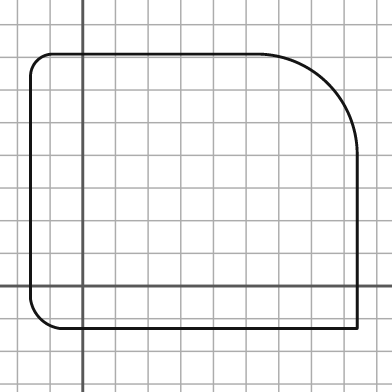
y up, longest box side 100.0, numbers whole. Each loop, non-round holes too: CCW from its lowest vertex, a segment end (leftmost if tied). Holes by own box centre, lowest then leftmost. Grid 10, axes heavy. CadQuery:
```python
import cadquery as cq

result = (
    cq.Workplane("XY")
    .moveTo(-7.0, -13.0)
    .lineTo(84.0, -13.0)
    .lineTo(84.0, 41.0)
    .threePointArc((75.0, 62.0), (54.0, 71.0))
    .lineTo(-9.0, 71.0)
    .threePointArc((-14.0, 69.0), (-16.0, 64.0))
    .lineTo(-16.0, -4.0)
    .threePointArc((-13.0, -10.0), (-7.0, -13.0))
    .close()
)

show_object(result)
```